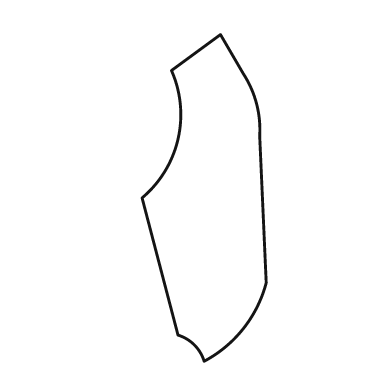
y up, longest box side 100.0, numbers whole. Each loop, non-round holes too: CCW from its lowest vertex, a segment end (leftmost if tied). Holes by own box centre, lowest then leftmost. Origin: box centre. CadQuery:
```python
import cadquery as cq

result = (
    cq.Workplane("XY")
    .moveTo(0.0, -50.0)
    .threePointArc((12.0, -40.0), (19.0, -26.0))
    .lineTo(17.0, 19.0)
    .threePointArc((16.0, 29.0), (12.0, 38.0))
    .lineTo(5.0, 50.0)
    .lineTo(-10.0, 39.0)
    .threePointArc((-8.0, 18.0), (-19.0, 0.0))
    .lineTo(-8.0, -42.0)
    .threePointArc((-3.0, -45.0), (0.0, -50.0))
    .close()
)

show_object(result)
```